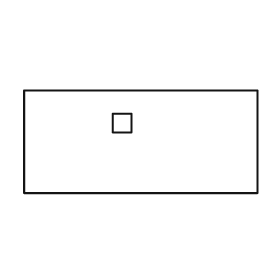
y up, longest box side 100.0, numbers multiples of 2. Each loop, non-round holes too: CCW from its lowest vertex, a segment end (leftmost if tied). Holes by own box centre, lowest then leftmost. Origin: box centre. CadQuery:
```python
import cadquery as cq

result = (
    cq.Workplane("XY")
    .moveTo(-50.0, -22.0)
    .lineTo(50.0, -22.0)
    .lineTo(50.0, 22.0)
    .lineTo(-50.0, 22.0)
    .close()
    .moveTo(-12.0, 4.0)
    .lineTo(-4.0, 4.0)
    .lineTo(-4.0, 12.0)
    .lineTo(-12.0, 12.0)
    .close()
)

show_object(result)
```